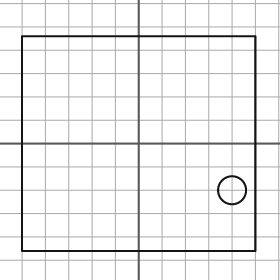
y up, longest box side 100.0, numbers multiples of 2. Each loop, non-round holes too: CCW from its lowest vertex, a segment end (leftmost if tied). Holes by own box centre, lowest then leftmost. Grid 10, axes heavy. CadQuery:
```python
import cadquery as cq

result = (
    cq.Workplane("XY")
    .moveTo(-50.0, -46.0)
    .lineTo(50.0, -46.0)
    .lineTo(50.0, 46.0)
    .lineTo(-50.0, 46.0)
    .close()
    .moveTo(40.0, -20.0)
    .circle(6.0)
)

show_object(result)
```